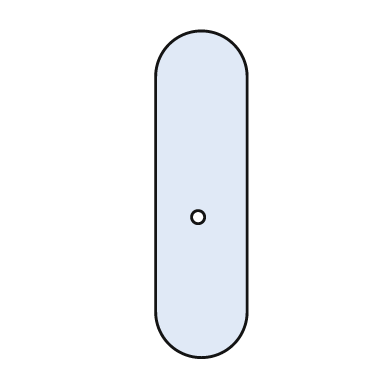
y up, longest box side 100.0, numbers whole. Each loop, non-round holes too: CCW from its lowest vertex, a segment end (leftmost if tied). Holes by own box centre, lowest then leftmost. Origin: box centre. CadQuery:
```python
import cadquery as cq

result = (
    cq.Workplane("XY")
    .moveTo(-14.0, -36.0)
    .threePointArc((0.0, -50.0), (14.0, -36.0))
    .lineTo(14.0, 36.0)
    .threePointArc((0.0, 50.0), (-14.0, 36.0))
    .close()
    .moveTo(-1.0, -7.0)
    .circle(2.0)
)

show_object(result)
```